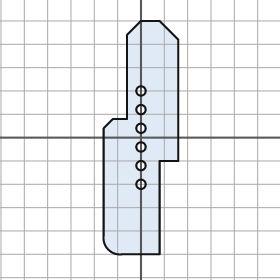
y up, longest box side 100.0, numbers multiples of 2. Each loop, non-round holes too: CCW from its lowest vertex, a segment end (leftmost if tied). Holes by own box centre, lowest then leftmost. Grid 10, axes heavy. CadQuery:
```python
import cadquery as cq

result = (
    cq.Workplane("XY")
    .moveTo(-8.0, -50.0)
    .lineTo(8.0, -50.0)
    .lineTo(8.0, -10.0)
    .lineTo(16.0, -10.0)
    .lineTo(16.0, 42.0)
    .lineTo(8.0, 50.0)
    .lineTo(0.0, 50.0)
    .lineTo(-6.0, 44.0)
    .lineTo(-6.0, 8.0)
    .lineTo(-12.0, 8.0)
    .lineTo(-16.0, 4.0)
    .lineTo(-16.0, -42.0)
    .threePointArc((-14.0, -48.0), (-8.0, -50.0))
    .close()
    .moveTo(0.0, -20.0)
    .circle(2.0)
    .moveTo(0.0, -12.0)
    .circle(2.0)
    .moveTo(0.0, -4.0)
    .circle(2.0)
    .moveTo(0.0, 4.0)
    .circle(2.0)
    .moveTo(0.0, 12.0)
    .circle(2.0)
    .moveTo(0.0, 20.0)
    .circle(2.0)
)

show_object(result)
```